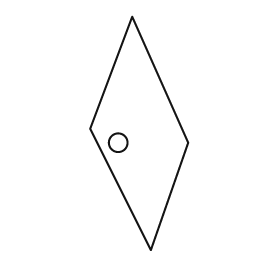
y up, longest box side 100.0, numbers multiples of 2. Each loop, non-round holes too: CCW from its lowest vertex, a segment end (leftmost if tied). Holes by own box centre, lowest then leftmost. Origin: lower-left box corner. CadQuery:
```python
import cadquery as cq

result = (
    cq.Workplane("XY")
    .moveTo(26.0, 0.0)
    .lineTo(42.0, 46.0)
    .lineTo(18.0, 100.0)
    .lineTo(0.0, 52.0)
    .close()
    .moveTo(12.0, 46.0)
    .circle(4.0)
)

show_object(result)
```